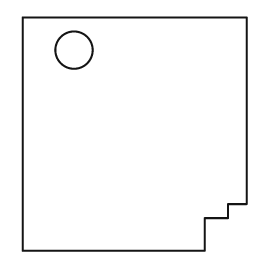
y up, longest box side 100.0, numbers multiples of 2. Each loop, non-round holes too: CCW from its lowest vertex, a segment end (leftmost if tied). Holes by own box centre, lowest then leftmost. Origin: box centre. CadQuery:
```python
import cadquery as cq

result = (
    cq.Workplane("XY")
    .moveTo(-48.0, -50.0)
    .lineTo(30.0, -50.0)
    .lineTo(30.0, -36.0)
    .lineTo(40.0, -36.0)
    .lineTo(40.0, -30.0)
    .lineTo(48.0, -30.0)
    .lineTo(48.0, 50.0)
    .lineTo(-48.0, 50.0)
    .close()
    .moveTo(-26.0, 36.0)
    .circle(8.0)
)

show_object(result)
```